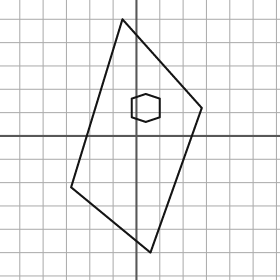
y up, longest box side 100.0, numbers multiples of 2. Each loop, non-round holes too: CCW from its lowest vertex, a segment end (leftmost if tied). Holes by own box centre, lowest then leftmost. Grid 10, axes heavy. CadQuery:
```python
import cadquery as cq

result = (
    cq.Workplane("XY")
    .moveTo(6.0, -50.0)
    .lineTo(28.0, 12.0)
    .lineTo(-6.0, 50.0)
    .lineTo(-28.0, -22.0)
    .close()
    .moveTo(4.0, 6.0)
    .lineTo(10.0, 8.0)
    .lineTo(10.0, 16.0)
    .lineTo(4.0, 18.0)
    .lineTo(-2.0, 16.0)
    .lineTo(-2.0, 8.0)
    .close()
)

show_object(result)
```